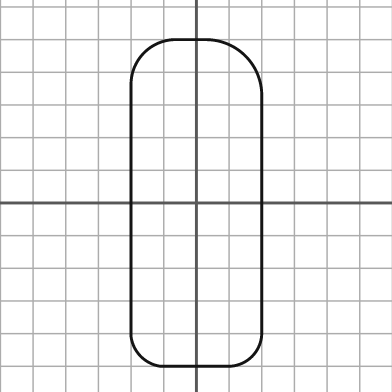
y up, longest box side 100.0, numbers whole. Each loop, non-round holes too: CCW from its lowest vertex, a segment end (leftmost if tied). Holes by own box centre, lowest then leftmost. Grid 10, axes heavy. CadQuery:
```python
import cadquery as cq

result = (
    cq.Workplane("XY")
    .moveTo(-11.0, -50.0)
    .lineTo(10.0, -50.0)
    .threePointArc((17.0, -47.0), (20.0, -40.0))
    .lineTo(20.0, 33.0)
    .threePointArc((15.0, 45.0), (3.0, 50.0))
    .lineTo(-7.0, 50.0)
    .threePointArc((-16.0, 46.0), (-20.0, 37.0))
    .lineTo(-20.0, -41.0)
    .threePointArc((-17.0, -47.0), (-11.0, -50.0))
    .close()
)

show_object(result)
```